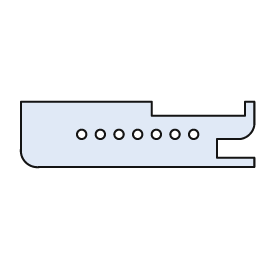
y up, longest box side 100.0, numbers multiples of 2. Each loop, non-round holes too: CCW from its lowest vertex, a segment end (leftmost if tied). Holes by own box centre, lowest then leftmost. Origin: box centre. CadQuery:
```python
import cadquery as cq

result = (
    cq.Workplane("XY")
    .moveTo(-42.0, -14.0)
    .lineTo(50.0, -14.0)
    .lineTo(50.0, -10.0)
    .lineTo(34.0, -10.0)
    .lineTo(34.0, -2.0)
    .lineTo(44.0, -2.0)
    .threePointArc((48.0, 0.0), (50.0, 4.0))
    .lineTo(50.0, 14.0)
    .lineTo(46.0, 14.0)
    .lineTo(46.0, 8.0)
    .lineTo(6.0, 8.0)
    .lineTo(6.0, 14.0)
    .lineTo(-50.0, 14.0)
    .lineTo(-50.0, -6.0)
    .threePointArc((-48.0, -12.0), (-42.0, -14.0))
    .close()
    .moveTo(-24.0, 0.0)
    .circle(2.0)
    .moveTo(-16.0, 0.0)
    .circle(2.0)
    .moveTo(-8.0, 0.0)
    .circle(2.0)
    .moveTo(0.0, 0.0)
    .circle(2.0)
    .moveTo(8.0, 0.0)
    .circle(2.0)
    .moveTo(16.0, 0.0)
    .circle(2.0)
    .moveTo(24.0, 0.0)
    .circle(2.0)
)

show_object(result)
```